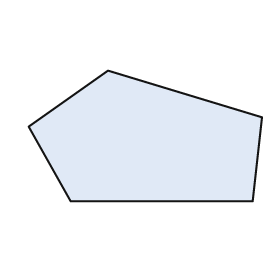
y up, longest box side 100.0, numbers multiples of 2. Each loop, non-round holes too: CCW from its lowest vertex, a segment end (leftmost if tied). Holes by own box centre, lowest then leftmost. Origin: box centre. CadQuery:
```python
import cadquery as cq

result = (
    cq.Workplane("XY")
    .moveTo(-32.0, -28.0)
    .lineTo(46.0, -28.0)
    .lineTo(50.0, 8.0)
    .lineTo(-16.0, 28.0)
    .lineTo(-50.0, 4.0)
    .close()
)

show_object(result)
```